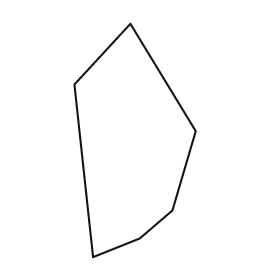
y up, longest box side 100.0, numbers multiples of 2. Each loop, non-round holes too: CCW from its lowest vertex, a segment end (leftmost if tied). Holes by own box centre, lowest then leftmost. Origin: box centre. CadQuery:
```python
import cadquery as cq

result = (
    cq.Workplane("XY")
    .moveTo(-18.0, -50.0)
    .lineTo(2.0, -42.0)
    .lineTo(16.0, -30.0)
    .lineTo(26.0, 4.0)
    .lineTo(-2.0, 50.0)
    .lineTo(-26.0, 24.0)
    .close()
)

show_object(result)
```